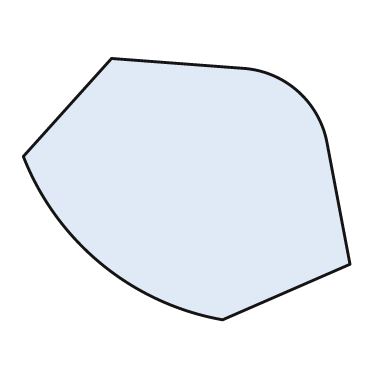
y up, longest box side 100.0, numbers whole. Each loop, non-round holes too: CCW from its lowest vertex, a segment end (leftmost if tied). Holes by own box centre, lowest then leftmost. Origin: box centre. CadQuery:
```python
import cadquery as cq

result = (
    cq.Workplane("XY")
    .moveTo(11.0, -40.0)
    .lineTo(50.0, -23.0)
    .lineTo(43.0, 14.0)
    .threePointArc((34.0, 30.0), (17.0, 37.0))
    .lineTo(-23.0, 40.0)
    .lineTo(-50.0, 10.0)
    .threePointArc((-26.0, -23.0), (11.0, -40.0))
    .close()
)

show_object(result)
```